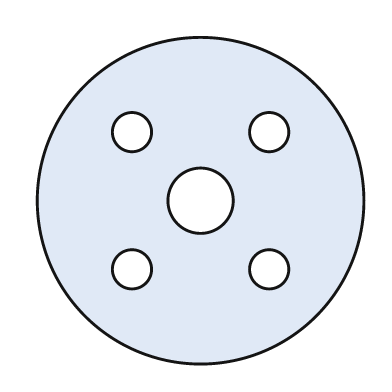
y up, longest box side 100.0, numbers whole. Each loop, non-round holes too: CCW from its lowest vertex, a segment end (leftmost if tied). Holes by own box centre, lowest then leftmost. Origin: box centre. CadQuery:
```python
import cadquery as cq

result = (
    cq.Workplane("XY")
    .moveTo(0.0, 0.0)
    .circle(50.0)
    .moveTo(-21.0, -21.0)
    .circle(6.0)
    .moveTo(21.0, -21.0)
    .circle(6.0)
    .moveTo(0.0, 0.0)
    .circle(10.0)
    .moveTo(-21.0, 21.0)
    .circle(6.0)
    .moveTo(21.0, 21.0)
    .circle(6.0)
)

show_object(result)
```